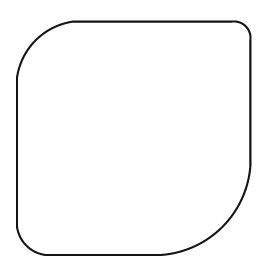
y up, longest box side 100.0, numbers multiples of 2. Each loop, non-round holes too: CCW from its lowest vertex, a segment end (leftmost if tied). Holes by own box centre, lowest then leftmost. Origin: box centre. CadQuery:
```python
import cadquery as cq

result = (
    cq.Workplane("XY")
    .moveTo(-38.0, -50.0)
    .lineTo(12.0, -50.0)
    .threePointArc((38.0, -38.0), (50.0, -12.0))
    .lineTo(50.0, 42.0)
    .threePointArc((48.0, 48.0), (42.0, 50.0))
    .lineTo(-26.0, 50.0)
    .threePointArc((-42.0, 42.0), (-50.0, 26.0))
    .lineTo(-50.0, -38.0)
    .threePointArc((-46.0, -46.0), (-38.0, -50.0))
    .close()
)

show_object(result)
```